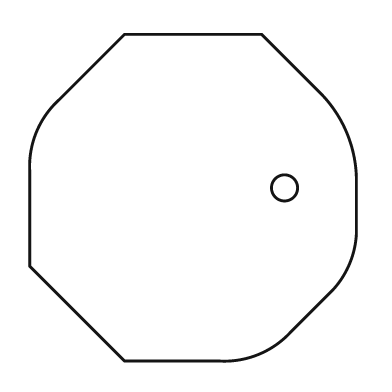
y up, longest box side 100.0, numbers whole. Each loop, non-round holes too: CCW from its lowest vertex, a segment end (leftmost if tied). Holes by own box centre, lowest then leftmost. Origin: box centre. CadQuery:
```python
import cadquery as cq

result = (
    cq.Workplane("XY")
    .moveTo(-21.0, -50.0)
    .lineTo(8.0, -50.0)
    .threePointArc((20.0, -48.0), (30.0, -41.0))
    .lineTo(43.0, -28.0)
    .threePointArc((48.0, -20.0), (50.0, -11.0))
    .lineTo(50.0, 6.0)
    .threePointArc((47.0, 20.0), (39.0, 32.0))
    .lineTo(21.0, 50.0)
    .lineTo(-21.0, 50.0)
    .lineTo(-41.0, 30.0)
    .threePointArc((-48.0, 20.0), (-50.0, 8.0))
    .lineTo(-50.0, -21.0)
    .close()
    .moveTo(28.0, 3.0)
    .circle(4.0)
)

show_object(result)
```